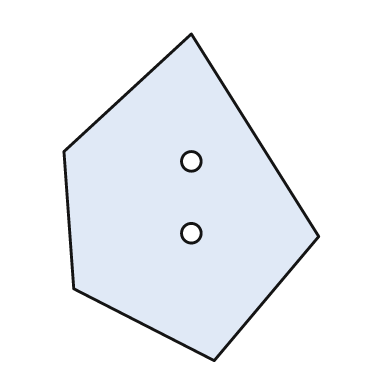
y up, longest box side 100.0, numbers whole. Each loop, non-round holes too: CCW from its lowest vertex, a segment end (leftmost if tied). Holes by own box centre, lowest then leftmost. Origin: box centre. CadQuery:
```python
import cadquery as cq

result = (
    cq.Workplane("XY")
    .moveTo(7.0, -50.0)
    .lineTo(39.0, -12.0)
    .lineTo(0.0, 50.0)
    .lineTo(-39.0, 14.0)
    .lineTo(-36.0, -28.0)
    .close()
    .moveTo(0.0, -11.0)
    .circle(3.0)
    .moveTo(0.0, 11.0)
    .circle(3.0)
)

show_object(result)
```